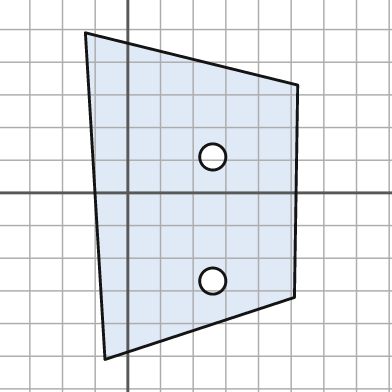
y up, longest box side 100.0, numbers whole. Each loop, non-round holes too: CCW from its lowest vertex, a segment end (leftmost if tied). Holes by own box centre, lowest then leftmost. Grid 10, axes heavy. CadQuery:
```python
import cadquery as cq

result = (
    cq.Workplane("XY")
    .moveTo(-7.0, -51.0)
    .lineTo(51.0, -32.0)
    .lineTo(52.0, 33.0)
    .lineTo(-13.0, 49.0)
    .close()
    .moveTo(26.0, -27.0)
    .circle(4.0)
    .moveTo(26.0, 11.0)
    .circle(4.0)
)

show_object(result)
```